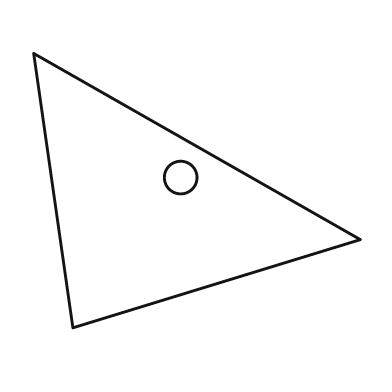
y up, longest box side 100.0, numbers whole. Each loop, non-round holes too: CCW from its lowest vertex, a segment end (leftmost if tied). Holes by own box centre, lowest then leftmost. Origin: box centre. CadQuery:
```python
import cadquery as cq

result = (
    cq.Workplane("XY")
    .moveTo(-38.0, -42.0)
    .lineTo(50.0, -15.0)
    .lineTo(-50.0, 42.0)
    .close()
    .moveTo(-5.0, 4.0)
    .circle(5.0)
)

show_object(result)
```